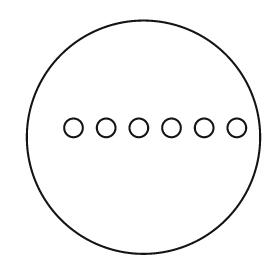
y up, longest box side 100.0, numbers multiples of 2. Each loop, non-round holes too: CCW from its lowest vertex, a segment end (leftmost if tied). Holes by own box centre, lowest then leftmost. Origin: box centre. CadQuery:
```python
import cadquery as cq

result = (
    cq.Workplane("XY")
    .moveTo(0.0, 0.0)
    .circle(50.0)
    .moveTo(-30.0, 4.0)
    .circle(4.0)
    .moveTo(-16.0, 4.0)
    .circle(4.0)
    .moveTo(-2.0, 4.0)
    .circle(4.0)
    .moveTo(12.0, 4.0)
    .circle(4.0)
    .moveTo(26.0, 4.0)
    .circle(4.0)
    .moveTo(40.0, 4.0)
    .circle(4.0)
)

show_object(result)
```